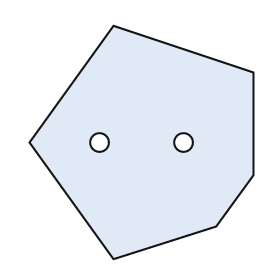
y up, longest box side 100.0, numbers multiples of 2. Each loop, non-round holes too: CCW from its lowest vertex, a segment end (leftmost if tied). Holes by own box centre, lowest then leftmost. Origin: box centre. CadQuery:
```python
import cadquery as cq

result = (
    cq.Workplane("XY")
    .moveTo(-12.0, -50.0)
    .lineTo(32.0, -36.0)
    .lineTo(48.0, -14.0)
    .lineTo(48.0, 30.0)
    .lineTo(-12.0, 50.0)
    .lineTo(-48.0, 0.0)
    .close()
    .moveTo(-18.0, 0.0)
    .circle(4.0)
    .moveTo(18.0, 0.0)
    .circle(4.0)
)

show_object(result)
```